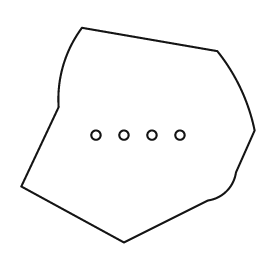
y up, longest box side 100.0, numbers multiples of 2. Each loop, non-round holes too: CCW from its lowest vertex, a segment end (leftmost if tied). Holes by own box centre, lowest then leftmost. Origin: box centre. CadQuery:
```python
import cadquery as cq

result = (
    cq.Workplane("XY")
    .moveTo(-6.0, -46.0)
    .lineTo(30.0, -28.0)
    .threePointArc((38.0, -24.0), (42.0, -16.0))
    .lineTo(50.0, 2.0)
    .threePointArc((44.0, 20.0), (34.0, 36.0))
    .lineTo(-24.0, 46.0)
    .threePointArc((-32.0, 30.0), (-34.0, 12.0))
    .lineTo(-50.0, -22.0)
    .close()
    .moveTo(-18.0, 0.0)
    .circle(2.0)
    .moveTo(-6.0, 0.0)
    .circle(2.0)
    .moveTo(6.0, 0.0)
    .circle(2.0)
    .moveTo(18.0, 0.0)
    .circle(2.0)
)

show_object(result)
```